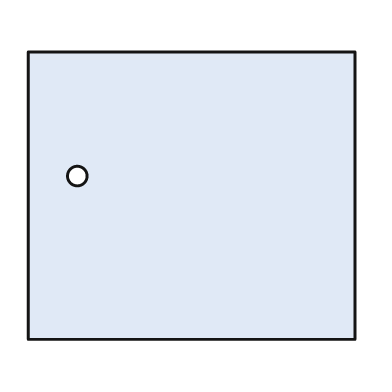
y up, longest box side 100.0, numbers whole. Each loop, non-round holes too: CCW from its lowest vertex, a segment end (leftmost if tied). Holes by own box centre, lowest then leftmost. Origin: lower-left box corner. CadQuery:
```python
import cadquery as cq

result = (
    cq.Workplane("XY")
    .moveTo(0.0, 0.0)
    .lineTo(100.0, 0.0)
    .lineTo(100.0, 88.0)
    .lineTo(0.0, 88.0)
    .close()
    .moveTo(15.0, 50.0)
    .circle(3.0)
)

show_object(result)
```